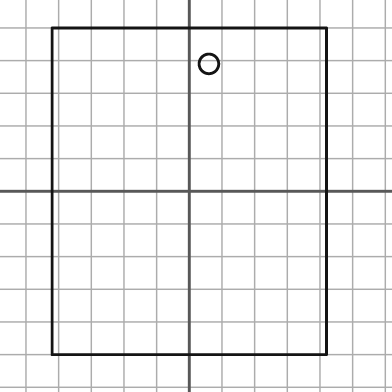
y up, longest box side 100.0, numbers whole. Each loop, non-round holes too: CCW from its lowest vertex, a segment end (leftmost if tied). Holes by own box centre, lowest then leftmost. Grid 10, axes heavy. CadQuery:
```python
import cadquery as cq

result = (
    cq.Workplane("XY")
    .moveTo(-42.0, -50.0)
    .lineTo(42.0, -50.0)
    .lineTo(42.0, 50.0)
    .lineTo(-42.0, 50.0)
    .close()
    .moveTo(6.0, 39.0)
    .circle(3.0)
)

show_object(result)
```